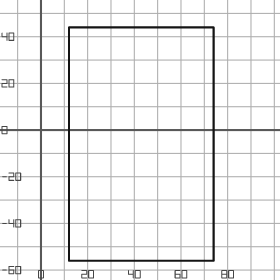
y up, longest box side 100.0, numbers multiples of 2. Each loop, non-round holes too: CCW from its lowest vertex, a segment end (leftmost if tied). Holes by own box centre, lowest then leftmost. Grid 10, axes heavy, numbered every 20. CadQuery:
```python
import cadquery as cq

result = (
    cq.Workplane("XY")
    .moveTo(12.0, -56.0)
    .lineTo(74.0, -56.0)
    .lineTo(74.0, 44.0)
    .lineTo(12.0, 44.0)
    .close()
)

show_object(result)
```